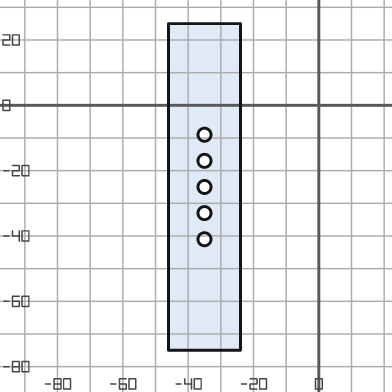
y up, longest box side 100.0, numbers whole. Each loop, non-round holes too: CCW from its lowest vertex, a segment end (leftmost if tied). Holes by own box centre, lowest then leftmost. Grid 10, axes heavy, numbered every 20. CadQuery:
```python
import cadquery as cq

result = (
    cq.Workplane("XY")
    .moveTo(-46.0, -75.0)
    .lineTo(-24.0, -75.0)
    .lineTo(-24.0, 25.0)
    .lineTo(-46.0, 25.0)
    .close()
    .moveTo(-35.0, -41.0)
    .circle(2.0)
    .moveTo(-35.0, -33.0)
    .circle(2.0)
    .moveTo(-35.0, -25.0)
    .circle(2.0)
    .moveTo(-35.0, -17.0)
    .circle(2.0)
    .moveTo(-35.0, -9.0)
    .circle(2.0)
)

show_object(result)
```